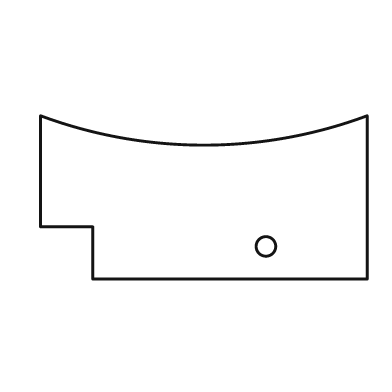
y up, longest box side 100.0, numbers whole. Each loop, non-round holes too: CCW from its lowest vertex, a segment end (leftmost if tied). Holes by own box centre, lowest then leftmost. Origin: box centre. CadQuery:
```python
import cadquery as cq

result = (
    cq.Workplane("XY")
    .moveTo(-34.0, -25.0)
    .lineTo(50.0, -25.0)
    .lineTo(50.0, 25.0)
    .threePointArc((0.0, 16.0), (-50.0, 25.0))
    .lineTo(-50.0, -9.0)
    .lineTo(-34.0, -9.0)
    .close()
    .moveTo(19.0, -15.0)
    .circle(3.0)
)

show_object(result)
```